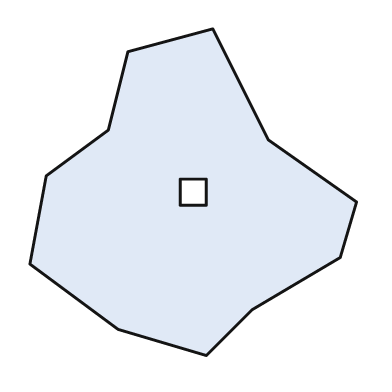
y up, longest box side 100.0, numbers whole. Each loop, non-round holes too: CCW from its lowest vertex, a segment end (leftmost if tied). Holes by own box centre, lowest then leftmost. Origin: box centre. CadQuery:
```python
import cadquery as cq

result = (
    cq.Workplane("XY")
    .moveTo(4.0, -50.0)
    .lineTo(18.0, -36.0)
    .lineTo(45.0, -20.0)
    .lineTo(50.0, -3.0)
    .lineTo(23.0, 16.0)
    .lineTo(6.0, 50.0)
    .lineTo(-20.0, 43.0)
    .lineTo(-26.0, 19.0)
    .lineTo(-45.0, 5.0)
    .lineTo(-50.0, -22.0)
    .lineTo(-23.0, -42.0)
    .close()
    .moveTo(-4.0, -4.0)
    .lineTo(4.0, -4.0)
    .lineTo(4.0, 4.0)
    .lineTo(-4.0, 4.0)
    .close()
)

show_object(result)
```